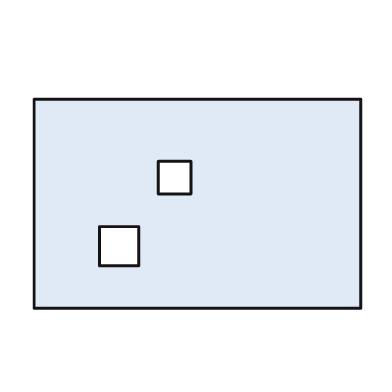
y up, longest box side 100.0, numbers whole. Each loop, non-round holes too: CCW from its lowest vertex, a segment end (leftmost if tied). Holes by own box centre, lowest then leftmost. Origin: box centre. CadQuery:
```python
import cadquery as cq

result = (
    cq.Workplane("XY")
    .moveTo(-50.0, -32.0)
    .lineTo(50.0, -32.0)
    .lineTo(50.0, 32.0)
    .lineTo(-50.0, 32.0)
    .close()
    .moveTo(-30.0, -19.0)
    .lineTo(-18.0, -19.0)
    .lineTo(-18.0, -7.0)
    .lineTo(-30.0, -7.0)
    .close()
    .moveTo(-12.0, 3.0)
    .lineTo(-2.0, 3.0)
    .lineTo(-2.0, 13.0)
    .lineTo(-12.0, 13.0)
    .close()
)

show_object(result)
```